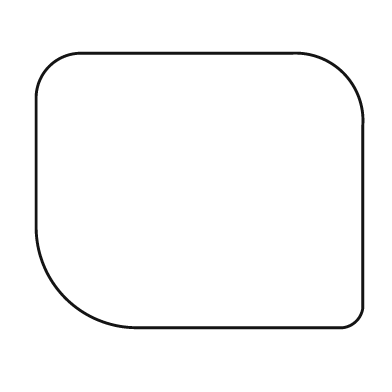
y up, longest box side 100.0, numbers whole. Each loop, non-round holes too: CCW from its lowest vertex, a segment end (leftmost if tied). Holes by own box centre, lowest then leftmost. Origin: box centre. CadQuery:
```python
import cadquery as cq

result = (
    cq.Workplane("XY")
    .moveTo(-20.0, -42.0)
    .lineTo(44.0, -42.0)
    .threePointArc((48.0, -40.0), (50.0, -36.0))
    .lineTo(50.0, 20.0)
    .threePointArc((44.0, 36.0), (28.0, 42.0))
    .lineTo(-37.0, 42.0)
    .threePointArc((-46.0, 38.0), (-50.0, 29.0))
    .lineTo(-50.0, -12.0)
    .threePointArc((-41.0, -33.0), (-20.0, -42.0))
    .close()
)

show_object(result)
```